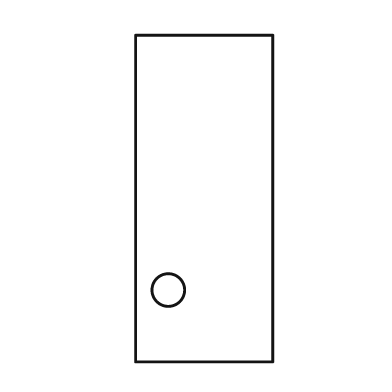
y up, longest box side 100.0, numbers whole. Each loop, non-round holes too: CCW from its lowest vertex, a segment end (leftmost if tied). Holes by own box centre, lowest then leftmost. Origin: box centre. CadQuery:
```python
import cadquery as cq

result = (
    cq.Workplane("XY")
    .moveTo(-21.0, -50.0)
    .lineTo(21.0, -50.0)
    .lineTo(21.0, 50.0)
    .lineTo(-21.0, 50.0)
    .close()
    .moveTo(-11.0, -28.0)
    .circle(5.0)
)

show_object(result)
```